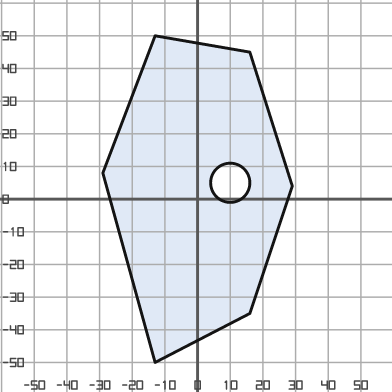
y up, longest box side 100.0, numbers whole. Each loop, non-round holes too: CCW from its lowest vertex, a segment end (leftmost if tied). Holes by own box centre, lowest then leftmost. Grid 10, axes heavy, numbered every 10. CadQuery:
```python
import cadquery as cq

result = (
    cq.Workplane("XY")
    .moveTo(-13.0, -50.0)
    .lineTo(16.0, -35.0)
    .lineTo(29.0, 4.0)
    .lineTo(16.0, 45.0)
    .lineTo(-13.0, 50.0)
    .lineTo(-29.0, 8.0)
    .close()
    .moveTo(10.0, 5.0)
    .circle(6.0)
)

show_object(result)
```